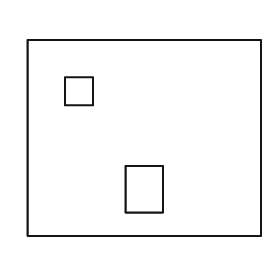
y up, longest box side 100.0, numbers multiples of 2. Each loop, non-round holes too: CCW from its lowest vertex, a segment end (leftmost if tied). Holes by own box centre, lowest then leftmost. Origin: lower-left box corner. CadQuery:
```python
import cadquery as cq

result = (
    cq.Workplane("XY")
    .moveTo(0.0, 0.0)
    .lineTo(100.0, 0.0)
    .lineTo(100.0, 84.0)
    .lineTo(0.0, 84.0)
    .close()
    .moveTo(42.0, 10.0)
    .lineTo(58.0, 10.0)
    .lineTo(58.0, 30.0)
    .lineTo(42.0, 30.0)
    .close()
    .moveTo(16.0, 56.0)
    .lineTo(28.0, 56.0)
    .lineTo(28.0, 68.0)
    .lineTo(16.0, 68.0)
    .close()
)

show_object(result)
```